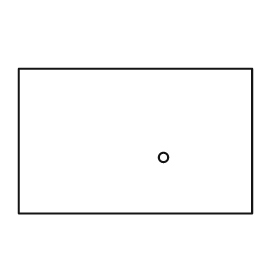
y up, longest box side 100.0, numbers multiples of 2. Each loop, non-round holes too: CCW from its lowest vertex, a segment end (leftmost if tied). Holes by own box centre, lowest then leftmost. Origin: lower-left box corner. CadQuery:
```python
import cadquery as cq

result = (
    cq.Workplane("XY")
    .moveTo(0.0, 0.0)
    .lineTo(100.0, 0.0)
    .lineTo(100.0, 62.0)
    .lineTo(0.0, 62.0)
    .close()
    .moveTo(62.0, 24.0)
    .circle(2.0)
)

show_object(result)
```